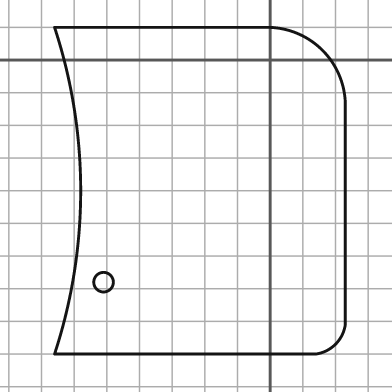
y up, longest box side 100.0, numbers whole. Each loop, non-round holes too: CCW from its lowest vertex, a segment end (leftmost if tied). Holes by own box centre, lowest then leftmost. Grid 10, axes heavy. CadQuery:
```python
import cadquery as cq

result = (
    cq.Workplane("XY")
    .moveTo(-66.0, -90.0)
    .lineTo(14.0, -90.0)
    .threePointArc((20.0, -87.0), (23.0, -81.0))
    .lineTo(23.0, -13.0)
    .threePointArc((16.0, 3.0), (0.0, 10.0))
    .lineTo(-66.0, 10.0)
    .threePointArc((-58.0, -40.0), (-66.0, -90.0))
    .close()
    .moveTo(-51.0, -68.0)
    .circle(3.0)
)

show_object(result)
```